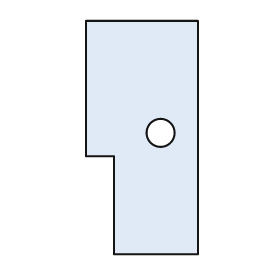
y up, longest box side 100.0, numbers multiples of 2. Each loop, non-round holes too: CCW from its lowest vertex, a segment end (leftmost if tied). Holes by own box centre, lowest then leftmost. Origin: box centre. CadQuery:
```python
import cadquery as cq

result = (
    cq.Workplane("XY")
    .moveTo(-12.0, -50.0)
    .lineTo(24.0, -50.0)
    .lineTo(24.0, 50.0)
    .lineTo(-24.0, 50.0)
    .lineTo(-24.0, -8.0)
    .lineTo(-12.0, -8.0)
    .close()
    .moveTo(8.0, 2.0)
    .circle(6.0)
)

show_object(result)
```